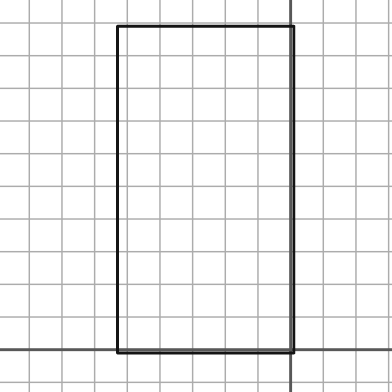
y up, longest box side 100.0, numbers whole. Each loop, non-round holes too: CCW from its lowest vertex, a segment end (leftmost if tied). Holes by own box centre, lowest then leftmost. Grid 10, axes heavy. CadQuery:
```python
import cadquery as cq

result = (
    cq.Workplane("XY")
    .moveTo(-53.0, -1.0)
    .lineTo(1.0, -1.0)
    .lineTo(1.0, 99.0)
    .lineTo(-53.0, 99.0)
    .close()
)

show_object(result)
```